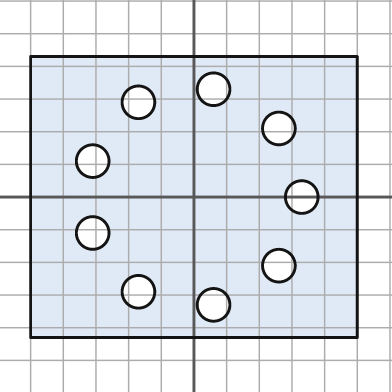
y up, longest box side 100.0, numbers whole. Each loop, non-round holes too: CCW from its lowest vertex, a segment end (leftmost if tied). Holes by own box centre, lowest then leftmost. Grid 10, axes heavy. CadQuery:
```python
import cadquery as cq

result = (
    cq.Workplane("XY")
    .moveTo(-50.0, -43.0)
    .lineTo(50.0, -43.0)
    .lineTo(50.0, 43.0)
    .lineTo(-50.0, 43.0)
    .close()
    .moveTo(6.0, -33.0)
    .circle(5.0)
    .moveTo(-17.0, -29.0)
    .circle(5.0)
    .moveTo(26.0, -21.0)
    .circle(5.0)
    .moveTo(-31.0, -11.0)
    .circle(5.0)
    .moveTo(33.0, 0.0)
    .circle(5.0)
    .moveTo(-31.0, 11.0)
    .circle(5.0)
    .moveTo(26.0, 21.0)
    .circle(5.0)
    .moveTo(-17.0, 29.0)
    .circle(5.0)
    .moveTo(6.0, 33.0)
    .circle(5.0)
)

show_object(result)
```